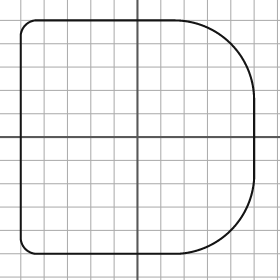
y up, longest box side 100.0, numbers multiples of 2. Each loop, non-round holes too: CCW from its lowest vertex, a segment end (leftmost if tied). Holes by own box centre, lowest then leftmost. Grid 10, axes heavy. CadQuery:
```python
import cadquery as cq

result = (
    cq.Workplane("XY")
    .moveTo(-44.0, -50.0)
    .lineTo(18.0, -50.0)
    .threePointArc((40.0, -40.0), (50.0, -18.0))
    .lineTo(50.0, 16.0)
    .threePointArc((40.0, 40.0), (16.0, 50.0))
    .lineTo(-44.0, 50.0)
    .threePointArc((-48.0, 48.0), (-50.0, 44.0))
    .lineTo(-50.0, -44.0)
    .threePointArc((-48.0, -48.0), (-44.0, -50.0))
    .close()
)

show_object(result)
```